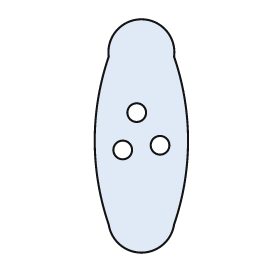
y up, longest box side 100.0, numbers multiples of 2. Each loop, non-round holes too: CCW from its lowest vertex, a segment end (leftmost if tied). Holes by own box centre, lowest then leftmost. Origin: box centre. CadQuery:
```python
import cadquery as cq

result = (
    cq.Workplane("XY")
    .moveTo(-14.0, -38.0)
    .threePointArc((0.0, -50.0), (14.0, -38.0))
    .threePointArc((20.0, -2.0), (14.0, 34.0))
    .threePointArc((0.0, 50.0), (-14.0, 34.0))
    .threePointArc((-20.0, -2.0), (-14.0, -38.0))
    .close()
    .moveTo(-8.0, -6.0)
    .circle(4.0)
    .moveTo(8.0, -4.0)
    .circle(4.0)
    .moveTo(-2.0, 10.0)
    .circle(4.0)
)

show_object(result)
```